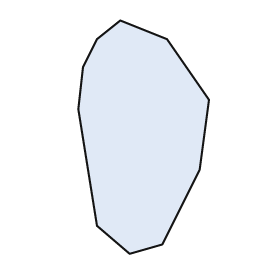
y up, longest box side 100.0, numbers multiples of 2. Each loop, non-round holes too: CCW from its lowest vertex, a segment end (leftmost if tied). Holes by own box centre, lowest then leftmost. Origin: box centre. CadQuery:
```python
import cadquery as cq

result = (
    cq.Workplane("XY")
    .moveTo(-6.0, -50.0)
    .lineTo(8.0, -46.0)
    .lineTo(24.0, -14.0)
    .lineTo(28.0, 16.0)
    .lineTo(10.0, 42.0)
    .lineTo(-10.0, 50.0)
    .lineTo(-20.0, 42.0)
    .lineTo(-26.0, 30.0)
    .lineTo(-28.0, 12.0)
    .lineTo(-20.0, -38.0)
    .close()
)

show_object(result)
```